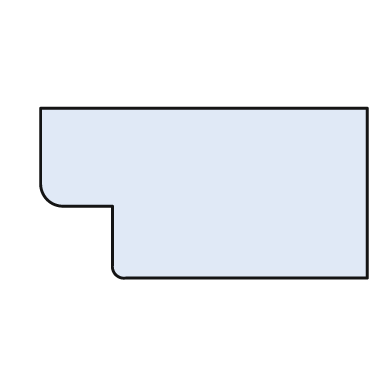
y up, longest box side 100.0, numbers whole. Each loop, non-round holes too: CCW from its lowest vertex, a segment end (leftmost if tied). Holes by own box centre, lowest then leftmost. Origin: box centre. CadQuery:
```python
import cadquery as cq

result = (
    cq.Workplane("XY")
    .moveTo(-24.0, -26.0)
    .lineTo(50.0, -26.0)
    .lineTo(50.0, 26.0)
    .lineTo(-50.0, 26.0)
    .lineTo(-50.0, 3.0)
    .threePointArc((-48.0, -2.0), (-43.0, -4.0))
    .lineTo(-28.0, -4.0)
    .lineTo(-28.0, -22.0)
    .threePointArc((-27.0, -25.0), (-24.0, -26.0))
    .close()
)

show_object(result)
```